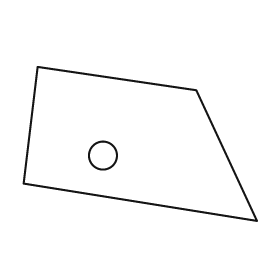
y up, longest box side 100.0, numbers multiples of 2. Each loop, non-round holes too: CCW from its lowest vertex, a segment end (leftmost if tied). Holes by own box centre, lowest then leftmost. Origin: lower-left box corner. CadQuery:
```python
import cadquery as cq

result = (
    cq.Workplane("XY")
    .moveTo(100.0, 0.0)
    .lineTo(74.0, 56.0)
    .lineTo(6.0, 66.0)
    .lineTo(0.0, 16.0)
    .close()
    .moveTo(34.0, 28.0)
    .circle(6.0)
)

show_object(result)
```